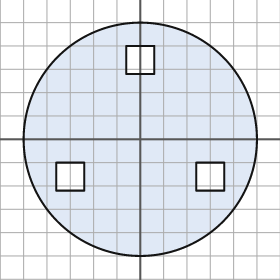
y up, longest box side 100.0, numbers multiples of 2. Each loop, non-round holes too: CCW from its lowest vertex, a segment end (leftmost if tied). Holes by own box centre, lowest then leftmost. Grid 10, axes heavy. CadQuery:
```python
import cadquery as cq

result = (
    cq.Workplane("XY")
    .moveTo(0.0, 0.0)
    .circle(50.0)
    .moveTo(-36.0, -22.0)
    .lineTo(-24.0, -22.0)
    .lineTo(-24.0, -10.0)
    .lineTo(-36.0, -10.0)
    .close()
    .moveTo(24.0, -22.0)
    .lineTo(36.0, -22.0)
    .lineTo(36.0, -10.0)
    .lineTo(24.0, -10.0)
    .close()
    .moveTo(-6.0, 28.0)
    .lineTo(6.0, 28.0)
    .lineTo(6.0, 40.0)
    .lineTo(-6.0, 40.0)
    .close()
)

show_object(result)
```